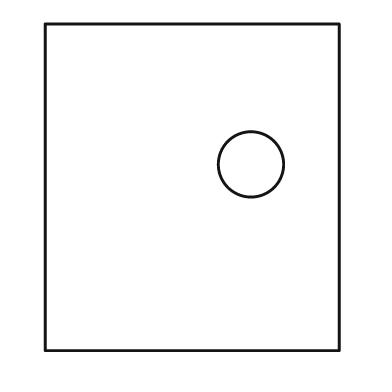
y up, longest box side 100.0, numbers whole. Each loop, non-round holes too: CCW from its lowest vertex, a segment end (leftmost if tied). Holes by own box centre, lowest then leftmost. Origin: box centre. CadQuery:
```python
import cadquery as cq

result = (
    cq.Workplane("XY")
    .moveTo(-45.0, -50.0)
    .lineTo(45.0, -50.0)
    .lineTo(45.0, 50.0)
    .lineTo(-45.0, 50.0)
    .close()
    .moveTo(18.0, 7.0)
    .circle(10.0)
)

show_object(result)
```